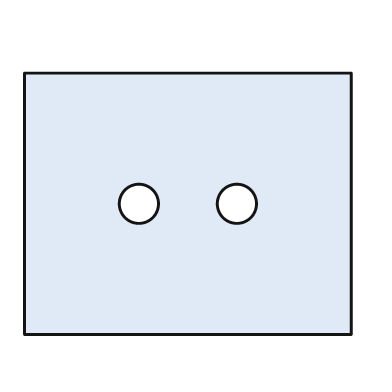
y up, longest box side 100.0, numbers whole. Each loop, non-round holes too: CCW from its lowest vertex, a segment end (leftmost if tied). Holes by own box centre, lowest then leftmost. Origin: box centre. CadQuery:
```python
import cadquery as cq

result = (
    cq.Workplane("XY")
    .moveTo(-50.0, -40.0)
    .lineTo(50.0, -40.0)
    .lineTo(50.0, 40.0)
    .lineTo(-50.0, 40.0)
    .close()
    .moveTo(-15.0, 0.0)
    .circle(6.0)
    .moveTo(15.0, 0.0)
    .circle(6.0)
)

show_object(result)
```